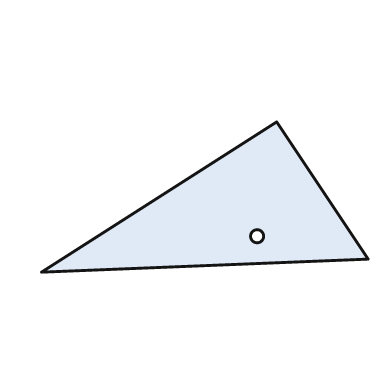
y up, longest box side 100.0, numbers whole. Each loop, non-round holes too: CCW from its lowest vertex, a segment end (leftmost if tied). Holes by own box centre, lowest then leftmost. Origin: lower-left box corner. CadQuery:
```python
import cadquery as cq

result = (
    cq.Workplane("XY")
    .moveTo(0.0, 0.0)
    .lineTo(100.0, 4.0)
    .lineTo(72.0, 46.0)
    .close()
    .moveTo(66.0, 11.0)
    .circle(2.0)
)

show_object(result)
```